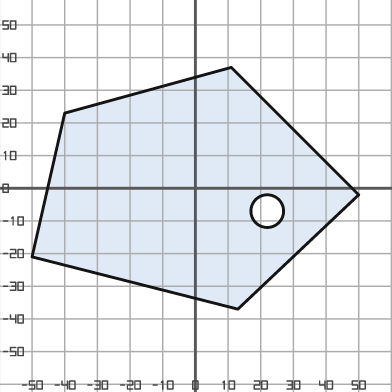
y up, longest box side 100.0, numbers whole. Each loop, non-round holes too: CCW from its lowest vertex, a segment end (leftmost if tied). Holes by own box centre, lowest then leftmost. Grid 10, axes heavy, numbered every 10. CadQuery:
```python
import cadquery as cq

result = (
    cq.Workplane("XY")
    .moveTo(13.0, -37.0)
    .lineTo(50.0, -2.0)
    .lineTo(11.0, 37.0)
    .lineTo(-40.0, 23.0)
    .lineTo(-50.0, -21.0)
    .close()
    .moveTo(22.0, -7.0)
    .circle(5.0)
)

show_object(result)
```